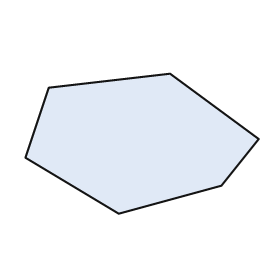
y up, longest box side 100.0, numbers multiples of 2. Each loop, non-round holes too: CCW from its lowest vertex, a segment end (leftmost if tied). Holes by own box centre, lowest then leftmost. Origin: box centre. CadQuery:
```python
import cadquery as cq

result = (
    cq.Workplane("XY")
    .moveTo(-10.0, -30.0)
    .lineTo(34.0, -18.0)
    .lineTo(50.0, 2.0)
    .lineTo(12.0, 30.0)
    .lineTo(-40.0, 24.0)
    .lineTo(-50.0, -6.0)
    .close()
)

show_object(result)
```